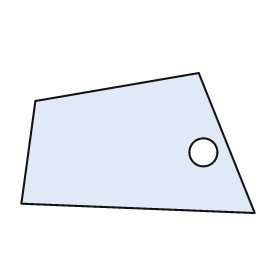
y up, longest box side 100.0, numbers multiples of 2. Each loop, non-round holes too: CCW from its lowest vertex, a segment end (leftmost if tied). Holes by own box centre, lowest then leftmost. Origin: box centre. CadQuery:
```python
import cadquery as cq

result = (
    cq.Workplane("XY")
    .moveTo(50.0, -30.0)
    .lineTo(26.0, 30.0)
    .lineTo(-44.0, 18.0)
    .lineTo(-50.0, -26.0)
    .close()
    .moveTo(28.0, -4.0)
    .circle(6.0)
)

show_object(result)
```